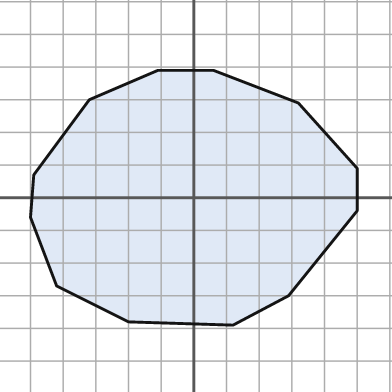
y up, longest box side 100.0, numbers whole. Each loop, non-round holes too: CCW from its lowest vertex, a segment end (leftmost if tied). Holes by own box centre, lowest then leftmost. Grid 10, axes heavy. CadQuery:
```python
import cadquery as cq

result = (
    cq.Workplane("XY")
    .moveTo(12.0, -39.0)
    .lineTo(29.0, -30.0)
    .lineTo(50.0, -4.0)
    .lineTo(50.0, 9.0)
    .lineTo(32.0, 29.0)
    .lineTo(6.0, 39.0)
    .lineTo(-11.0, 39.0)
    .lineTo(-32.0, 30.0)
    .lineTo(-49.0, 7.0)
    .lineTo(-50.0, -6.0)
    .lineTo(-42.0, -27.0)
    .lineTo(-20.0, -38.0)
    .close()
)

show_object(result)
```